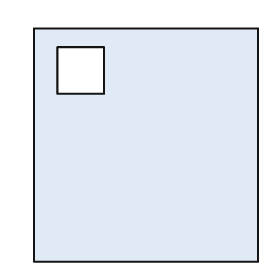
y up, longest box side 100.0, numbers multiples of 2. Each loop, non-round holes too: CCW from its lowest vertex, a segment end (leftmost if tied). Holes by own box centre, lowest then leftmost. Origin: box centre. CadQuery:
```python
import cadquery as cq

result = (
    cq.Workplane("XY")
    .moveTo(-48.0, -50.0)
    .lineTo(48.0, -50.0)
    .lineTo(48.0, 50.0)
    .lineTo(-48.0, 50.0)
    .close()
    .moveTo(-38.0, 22.0)
    .lineTo(-18.0, 22.0)
    .lineTo(-18.0, 42.0)
    .lineTo(-38.0, 42.0)
    .close()
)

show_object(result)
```